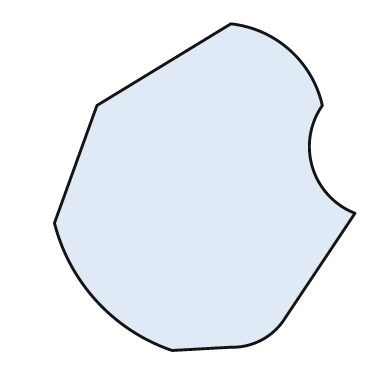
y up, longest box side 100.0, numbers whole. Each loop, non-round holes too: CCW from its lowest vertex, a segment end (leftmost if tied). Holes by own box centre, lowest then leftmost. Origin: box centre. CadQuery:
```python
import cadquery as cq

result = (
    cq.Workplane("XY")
    .moveTo(-10.0, -50.0)
    .lineTo(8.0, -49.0)
    .threePointArc((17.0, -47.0), (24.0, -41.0))
    .lineTo(46.0, -8.0)
    .threePointArc((33.0, 6.0), (36.0, 25.0))
    .threePointArc((26.0, 42.0), (8.0, 50.0))
    .lineTo(-33.0, 25.0)
    .lineTo(-46.0, -11.0)
    .threePointArc((-33.0, -35.0), (-10.0, -50.0))
    .close()
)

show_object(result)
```